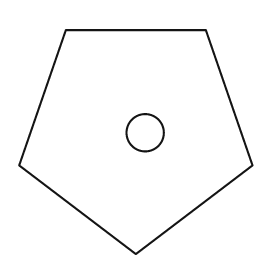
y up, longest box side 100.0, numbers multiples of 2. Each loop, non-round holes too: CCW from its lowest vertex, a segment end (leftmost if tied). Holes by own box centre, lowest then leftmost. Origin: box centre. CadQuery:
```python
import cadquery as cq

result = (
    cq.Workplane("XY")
    .moveTo(0.0, -48.0)
    .lineTo(50.0, -10.0)
    .lineTo(30.0, 48.0)
    .lineTo(-30.0, 48.0)
    .lineTo(-50.0, -10.0)
    .close()
    .moveTo(4.0, 4.0)
    .circle(8.0)
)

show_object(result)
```